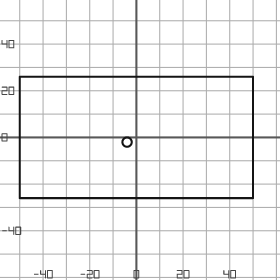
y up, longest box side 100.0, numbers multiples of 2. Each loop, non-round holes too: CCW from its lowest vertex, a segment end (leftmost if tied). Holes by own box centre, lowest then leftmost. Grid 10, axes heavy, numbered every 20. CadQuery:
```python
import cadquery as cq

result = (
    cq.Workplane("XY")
    .moveTo(-50.0, -26.0)
    .lineTo(50.0, -26.0)
    .lineTo(50.0, 26.0)
    .lineTo(-50.0, 26.0)
    .close()
    .moveTo(-4.0, -2.0)
    .circle(2.0)
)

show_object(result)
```